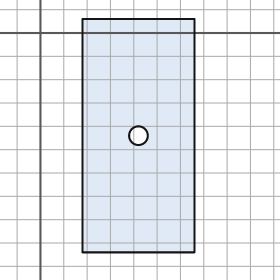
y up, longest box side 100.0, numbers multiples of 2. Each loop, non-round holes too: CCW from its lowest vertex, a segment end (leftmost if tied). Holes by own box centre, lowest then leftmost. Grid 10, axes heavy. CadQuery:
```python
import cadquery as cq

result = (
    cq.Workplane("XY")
    .moveTo(18.0, -94.0)
    .lineTo(66.0, -94.0)
    .lineTo(66.0, 6.0)
    .lineTo(18.0, 6.0)
    .close()
    .moveTo(42.0, -44.0)
    .circle(4.0)
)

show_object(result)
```